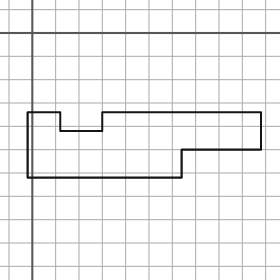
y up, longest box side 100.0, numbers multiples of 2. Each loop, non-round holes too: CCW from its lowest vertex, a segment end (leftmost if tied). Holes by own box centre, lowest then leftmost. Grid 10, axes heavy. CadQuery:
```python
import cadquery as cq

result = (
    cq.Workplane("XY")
    .moveTo(-2.0, -62.0)
    .lineTo(64.0, -62.0)
    .lineTo(64.0, -50.0)
    .lineTo(98.0, -50.0)
    .lineTo(98.0, -34.0)
    .lineTo(30.0, -34.0)
    .lineTo(30.0, -42.0)
    .lineTo(12.0, -42.0)
    .lineTo(12.0, -34.0)
    .lineTo(-2.0, -34.0)
    .close()
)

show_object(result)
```